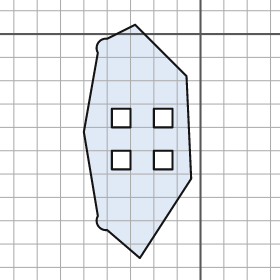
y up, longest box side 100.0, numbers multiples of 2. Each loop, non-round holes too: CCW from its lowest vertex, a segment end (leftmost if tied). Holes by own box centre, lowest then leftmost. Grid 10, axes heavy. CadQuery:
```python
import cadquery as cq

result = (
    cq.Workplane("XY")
    .moveTo(-26.0, -96.0)
    .lineTo(-4.0, -62.0)
    .lineTo(-6.0, -18.0)
    .lineTo(-28.0, 4.0)
    .lineTo(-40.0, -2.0)
    .threePointArc((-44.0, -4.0), (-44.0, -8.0))
    .lineTo(-50.0, -42.0)
    .lineTo(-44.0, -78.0)
    .threePointArc((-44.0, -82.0), (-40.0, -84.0))
    .close()
    .moveTo(-38.0, -58.0)
    .lineTo(-30.0, -58.0)
    .lineTo(-30.0, -50.0)
    .lineTo(-38.0, -50.0)
    .close()
    .moveTo(-20.0, -58.0)
    .lineTo(-12.0, -58.0)
    .lineTo(-12.0, -50.0)
    .lineTo(-20.0, -50.0)
    .close()
    .moveTo(-38.0, -40.0)
    .lineTo(-30.0, -40.0)
    .lineTo(-30.0, -32.0)
    .lineTo(-38.0, -32.0)
    .close()
    .moveTo(-20.0, -40.0)
    .lineTo(-12.0, -40.0)
    .lineTo(-12.0, -32.0)
    .lineTo(-20.0, -32.0)
    .close()
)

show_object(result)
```